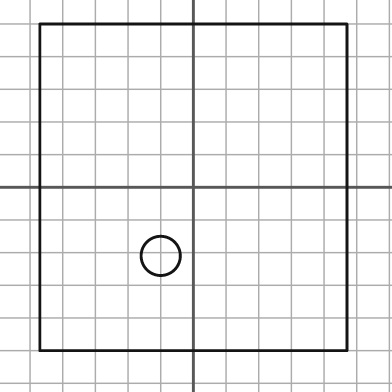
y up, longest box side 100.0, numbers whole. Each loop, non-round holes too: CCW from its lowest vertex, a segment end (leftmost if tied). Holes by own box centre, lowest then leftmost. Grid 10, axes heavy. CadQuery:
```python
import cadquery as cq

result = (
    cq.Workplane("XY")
    .moveTo(-47.0, -50.0)
    .lineTo(47.0, -50.0)
    .lineTo(47.0, 50.0)
    .lineTo(-47.0, 50.0)
    .close()
    .moveTo(-10.0, -21.0)
    .circle(6.0)
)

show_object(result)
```